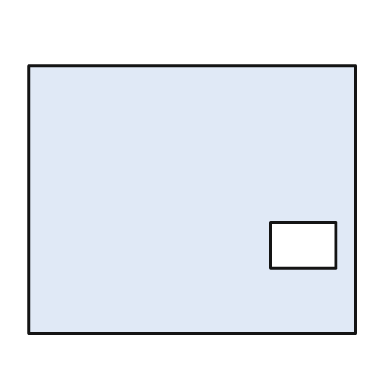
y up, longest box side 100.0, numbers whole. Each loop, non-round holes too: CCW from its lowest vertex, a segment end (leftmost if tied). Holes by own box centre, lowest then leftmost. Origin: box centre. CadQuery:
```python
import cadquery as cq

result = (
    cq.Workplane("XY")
    .moveTo(-50.0, -41.0)
    .lineTo(50.0, -41.0)
    .lineTo(50.0, 41.0)
    .lineTo(-50.0, 41.0)
    .close()
    .moveTo(24.0, -21.0)
    .lineTo(44.0, -21.0)
    .lineTo(44.0, -7.0)
    .lineTo(24.0, -7.0)
    .close()
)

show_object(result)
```